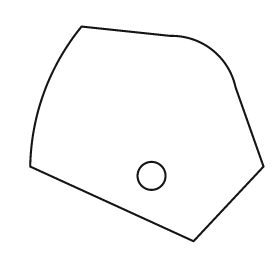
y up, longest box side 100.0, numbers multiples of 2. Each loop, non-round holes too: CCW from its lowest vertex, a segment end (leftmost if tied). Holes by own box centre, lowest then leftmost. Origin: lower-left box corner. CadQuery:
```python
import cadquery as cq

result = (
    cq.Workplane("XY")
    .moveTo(70.0, 0.0)
    .lineTo(100.0, 32.0)
    .lineTo(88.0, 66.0)
    .threePointArc((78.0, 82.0), (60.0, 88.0))
    .lineTo(22.0, 92.0)
    .threePointArc((6.0, 64.0), (0.0, 32.0))
    .close()
    .moveTo(52.0, 28.0)
    .circle(6.0)
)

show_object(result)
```